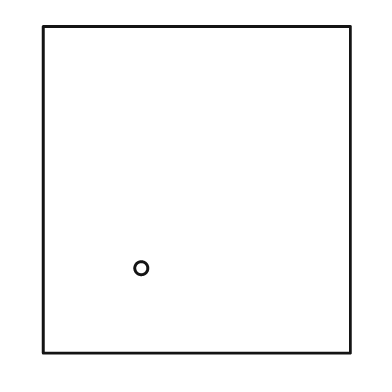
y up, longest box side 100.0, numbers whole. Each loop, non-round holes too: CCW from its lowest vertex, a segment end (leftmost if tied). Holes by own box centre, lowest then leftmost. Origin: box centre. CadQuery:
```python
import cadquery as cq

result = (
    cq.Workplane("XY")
    .moveTo(-47.0, -50.0)
    .lineTo(47.0, -50.0)
    .lineTo(47.0, 50.0)
    .lineTo(-47.0, 50.0)
    .close()
    .moveTo(-17.0, -24.0)
    .circle(2.0)
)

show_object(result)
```